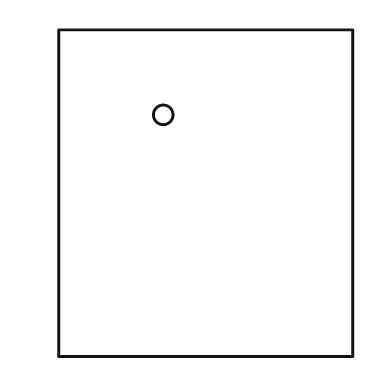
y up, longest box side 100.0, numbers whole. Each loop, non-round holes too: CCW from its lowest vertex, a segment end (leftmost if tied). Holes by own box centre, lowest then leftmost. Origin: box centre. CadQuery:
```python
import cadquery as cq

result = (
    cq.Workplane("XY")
    .moveTo(-45.0, -50.0)
    .lineTo(45.0, -50.0)
    .lineTo(45.0, 50.0)
    .lineTo(-45.0, 50.0)
    .close()
    .moveTo(-13.0, 24.0)
    .circle(3.0)
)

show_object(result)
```